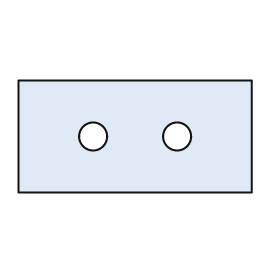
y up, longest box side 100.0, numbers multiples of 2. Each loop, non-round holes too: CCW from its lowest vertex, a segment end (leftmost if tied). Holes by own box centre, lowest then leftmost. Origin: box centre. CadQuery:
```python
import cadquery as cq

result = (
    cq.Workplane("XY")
    .moveTo(-50.0, -24.0)
    .lineTo(50.0, -24.0)
    .lineTo(50.0, 24.0)
    .lineTo(-50.0, 24.0)
    .close()
    .moveTo(-18.0, 0.0)
    .circle(6.0)
    .moveTo(18.0, 0.0)
    .circle(6.0)
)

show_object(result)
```